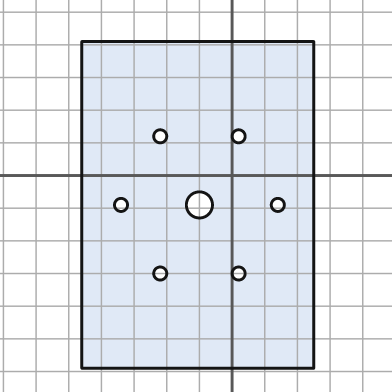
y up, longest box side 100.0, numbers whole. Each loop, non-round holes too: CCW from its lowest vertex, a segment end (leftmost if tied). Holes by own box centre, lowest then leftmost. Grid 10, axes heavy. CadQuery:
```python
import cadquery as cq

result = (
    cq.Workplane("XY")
    .moveTo(-46.0, -59.0)
    .lineTo(25.0, -59.0)
    .lineTo(25.0, 41.0)
    .lineTo(-46.0, 41.0)
    .close()
    .moveTo(-22.0, -30.0)
    .circle(2.0)
    .moveTo(2.0, -30.0)
    .circle(2.0)
    .moveTo(-34.0, -9.0)
    .circle(2.0)
    .moveTo(-10.0, -9.0)
    .circle(4.0)
    .moveTo(14.0, -9.0)
    .circle(2.0)
    .moveTo(-22.0, 12.0)
    .circle(2.0)
    .moveTo(2.0, 12.0)
    .circle(2.0)
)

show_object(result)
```